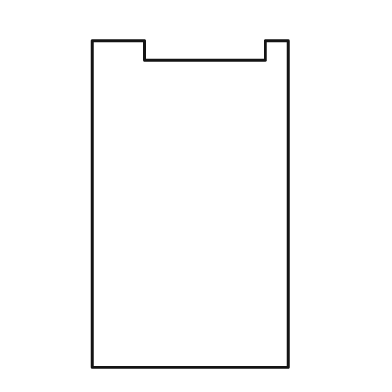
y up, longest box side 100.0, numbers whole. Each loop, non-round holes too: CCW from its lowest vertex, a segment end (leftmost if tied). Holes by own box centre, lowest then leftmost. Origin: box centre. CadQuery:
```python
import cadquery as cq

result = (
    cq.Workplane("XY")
    .moveTo(-30.0, -50.0)
    .lineTo(30.0, -50.0)
    .lineTo(30.0, 50.0)
    .lineTo(23.0, 50.0)
    .lineTo(23.0, 44.0)
    .lineTo(-14.0, 44.0)
    .lineTo(-14.0, 50.0)
    .lineTo(-30.0, 50.0)
    .close()
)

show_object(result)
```